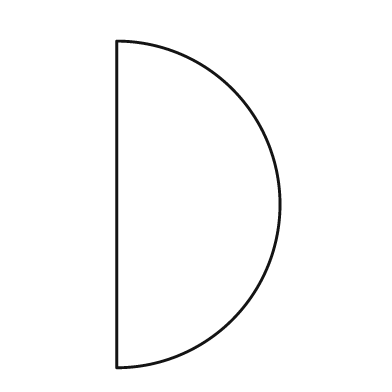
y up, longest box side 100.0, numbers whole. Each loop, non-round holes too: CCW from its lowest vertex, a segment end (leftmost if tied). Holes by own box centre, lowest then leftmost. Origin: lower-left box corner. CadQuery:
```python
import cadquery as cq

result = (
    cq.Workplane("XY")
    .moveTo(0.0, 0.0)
    .threePointArc((50.0, 50.0), (0.0, 100.0))
    .close()
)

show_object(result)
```